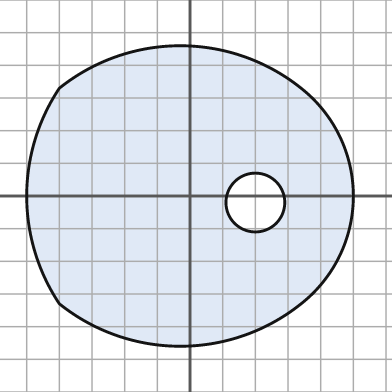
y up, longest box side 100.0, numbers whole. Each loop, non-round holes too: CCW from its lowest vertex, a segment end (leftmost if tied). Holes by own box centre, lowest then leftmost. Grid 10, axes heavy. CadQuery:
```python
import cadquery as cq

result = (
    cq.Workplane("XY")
    .moveTo(-40.0, -33.0)
    .threePointArc((-3.0, -46.0), (34.0, -33.0))
    .threePointArc((50.0, 0.0), (34.0, 33.0))
    .threePointArc((-3.0, 46.0), (-40.0, 33.0))
    .threePointArc((-50.0, 0.0), (-40.0, -33.0))
    .close()
    .moveTo(20.0, -2.0)
    .circle(9.0)
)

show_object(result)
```